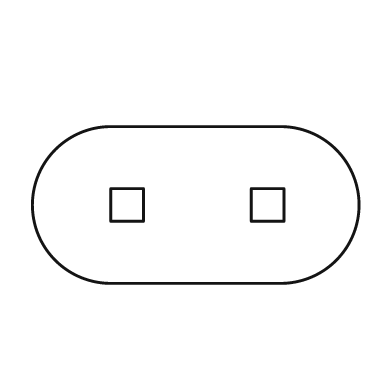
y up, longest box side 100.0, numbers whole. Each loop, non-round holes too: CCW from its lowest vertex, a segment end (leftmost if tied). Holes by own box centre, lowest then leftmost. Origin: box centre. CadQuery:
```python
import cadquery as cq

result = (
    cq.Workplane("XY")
    .moveTo(-26.0, -24.0)
    .lineTo(26.0, -24.0)
    .threePointArc((50.0, 0.0), (26.0, 24.0))
    .lineTo(-26.0, 24.0)
    .threePointArc((-50.0, 0.0), (-26.0, -24.0))
    .close()
    .moveTo(-26.0, -5.0)
    .lineTo(-16.0, -5.0)
    .lineTo(-16.0, 5.0)
    .lineTo(-26.0, 5.0)
    .close()
    .moveTo(17.0, -5.0)
    .lineTo(27.0, -5.0)
    .lineTo(27.0, 5.0)
    .lineTo(17.0, 5.0)
    .close()
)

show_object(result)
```